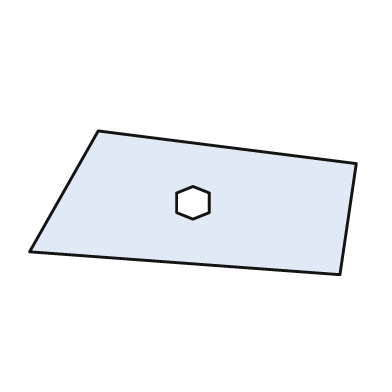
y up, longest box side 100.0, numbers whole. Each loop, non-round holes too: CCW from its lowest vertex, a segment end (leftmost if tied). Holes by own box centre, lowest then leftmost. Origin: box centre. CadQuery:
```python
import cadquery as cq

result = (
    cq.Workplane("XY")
    .moveTo(45.0, -22.0)
    .lineTo(50.0, 12.0)
    .lineTo(-29.0, 22.0)
    .lineTo(-50.0, -15.0)
    .close()
    .moveTo(0.0, -5.0)
    .lineTo(5.0, -3.0)
    .lineTo(5.0, 3.0)
    .lineTo(0.0, 5.0)
    .lineTo(-5.0, 3.0)
    .lineTo(-5.0, -3.0)
    .close()
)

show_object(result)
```